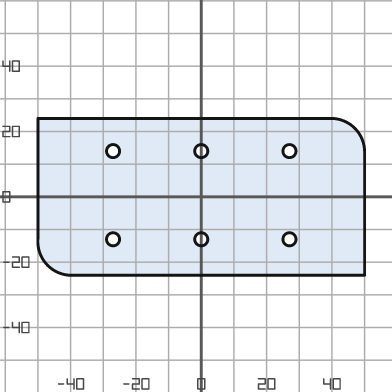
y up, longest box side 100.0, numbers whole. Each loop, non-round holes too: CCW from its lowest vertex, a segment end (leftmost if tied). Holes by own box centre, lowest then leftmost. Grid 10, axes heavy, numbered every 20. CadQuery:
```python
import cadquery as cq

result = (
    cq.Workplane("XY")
    .moveTo(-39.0, -24.0)
    .lineTo(50.0, -24.0)
    .lineTo(50.0, 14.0)
    .threePointArc((47.0, 21.0), (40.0, 24.0))
    .lineTo(-50.0, 24.0)
    .lineTo(-50.0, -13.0)
    .threePointArc((-47.0, -21.0), (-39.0, -24.0))
    .close()
    .moveTo(-27.0, -13.0)
    .circle(2.0)
    .moveTo(0.0, -13.0)
    .circle(2.0)
    .moveTo(27.0, -13.0)
    .circle(2.0)
    .moveTo(-27.0, 14.0)
    .circle(2.0)
    .moveTo(0.0, 14.0)
    .circle(2.0)
    .moveTo(27.0, 14.0)
    .circle(2.0)
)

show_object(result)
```